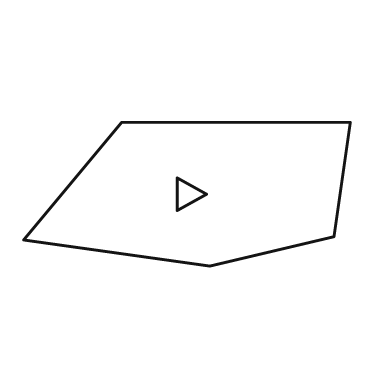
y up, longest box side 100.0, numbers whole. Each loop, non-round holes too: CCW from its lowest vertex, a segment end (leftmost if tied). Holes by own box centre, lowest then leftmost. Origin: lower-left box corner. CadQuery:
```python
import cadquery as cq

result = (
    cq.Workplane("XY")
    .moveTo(57.0, 0.0)
    .lineTo(95.0, 9.0)
    .lineTo(100.0, 44.0)
    .lineTo(30.0, 44.0)
    .lineTo(0.0, 8.0)
    .close()
    .moveTo(47.0, 17.0)
    .lineTo(56.0, 22.0)
    .lineTo(47.0, 27.0)
    .close()
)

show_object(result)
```